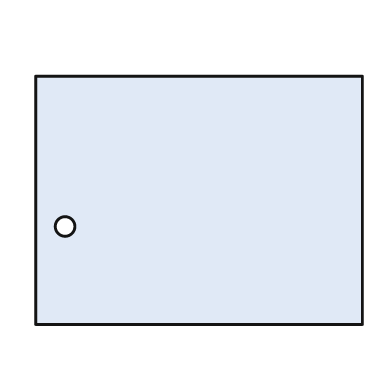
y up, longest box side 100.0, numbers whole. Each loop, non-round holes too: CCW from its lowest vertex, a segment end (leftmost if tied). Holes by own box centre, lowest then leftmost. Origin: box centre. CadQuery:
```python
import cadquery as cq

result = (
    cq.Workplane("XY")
    .moveTo(-50.0, -38.0)
    .lineTo(50.0, -38.0)
    .lineTo(50.0, 38.0)
    .lineTo(-50.0, 38.0)
    .close()
    .moveTo(-41.0, -8.0)
    .circle(3.0)
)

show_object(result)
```